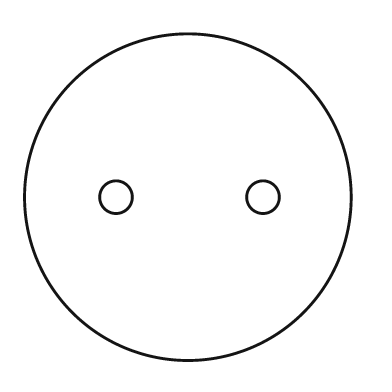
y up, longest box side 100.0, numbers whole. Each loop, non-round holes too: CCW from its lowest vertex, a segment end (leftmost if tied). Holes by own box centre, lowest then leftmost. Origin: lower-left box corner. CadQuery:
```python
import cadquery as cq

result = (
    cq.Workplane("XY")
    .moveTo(50.0, 50.0)
    .circle(50.0)
    .moveTo(28.0, 50.0)
    .circle(5.0)
    .moveTo(73.0, 50.0)
    .circle(5.0)
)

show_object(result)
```